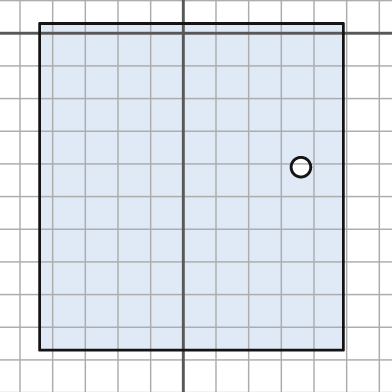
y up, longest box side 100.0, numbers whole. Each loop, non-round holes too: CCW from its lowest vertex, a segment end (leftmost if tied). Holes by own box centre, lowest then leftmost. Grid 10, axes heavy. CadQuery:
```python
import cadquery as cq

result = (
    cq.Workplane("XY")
    .moveTo(-44.0, -97.0)
    .lineTo(49.0, -97.0)
    .lineTo(49.0, 3.0)
    .lineTo(-44.0, 3.0)
    .close()
    .moveTo(36.0, -41.0)
    .circle(3.0)
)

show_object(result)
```